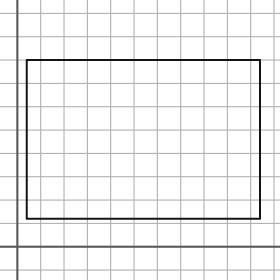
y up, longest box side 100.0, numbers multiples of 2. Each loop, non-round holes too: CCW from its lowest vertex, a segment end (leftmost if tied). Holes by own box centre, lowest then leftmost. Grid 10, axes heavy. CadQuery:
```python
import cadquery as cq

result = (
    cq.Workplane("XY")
    .moveTo(4.0, 12.0)
    .lineTo(104.0, 12.0)
    .lineTo(104.0, 80.0)
    .lineTo(4.0, 80.0)
    .close()
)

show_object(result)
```